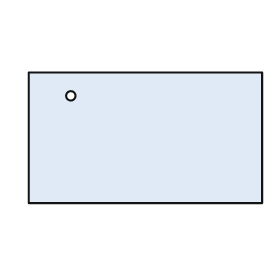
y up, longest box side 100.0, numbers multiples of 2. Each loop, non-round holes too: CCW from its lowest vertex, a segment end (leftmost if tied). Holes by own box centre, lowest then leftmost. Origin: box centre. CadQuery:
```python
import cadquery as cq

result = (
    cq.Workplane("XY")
    .moveTo(-50.0, -28.0)
    .lineTo(50.0, -28.0)
    .lineTo(50.0, 28.0)
    .lineTo(-50.0, 28.0)
    .close()
    .moveTo(-32.0, 18.0)
    .circle(2.0)
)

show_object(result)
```